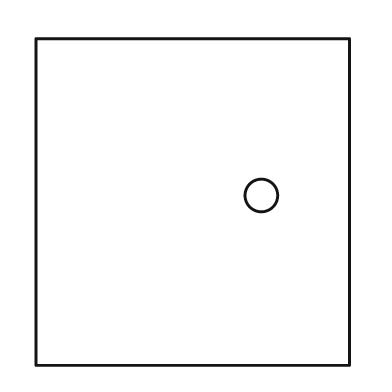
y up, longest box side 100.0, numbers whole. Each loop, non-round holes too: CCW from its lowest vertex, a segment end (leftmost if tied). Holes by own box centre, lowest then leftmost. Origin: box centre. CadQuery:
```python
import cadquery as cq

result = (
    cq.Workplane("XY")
    .moveTo(-48.0, -50.0)
    .lineTo(48.0, -50.0)
    .lineTo(48.0, 50.0)
    .lineTo(-48.0, 50.0)
    .close()
    .moveTo(21.0, 2.0)
    .circle(5.0)
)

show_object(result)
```